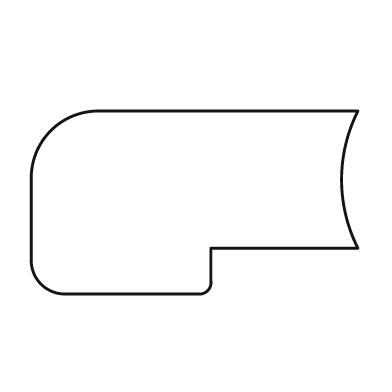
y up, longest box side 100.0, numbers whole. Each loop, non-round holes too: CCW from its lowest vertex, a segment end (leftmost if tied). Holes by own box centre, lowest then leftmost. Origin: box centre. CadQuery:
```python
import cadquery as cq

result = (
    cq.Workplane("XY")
    .moveTo(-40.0, -28.0)
    .lineTo(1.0, -28.0)
    .threePointArc((4.0, -27.0), (5.0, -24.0))
    .lineTo(5.0, -14.0)
    .lineTo(50.0, -14.0)
    .threePointArc((45.0, 7.0), (50.0, 28.0))
    .lineTo(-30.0, 28.0)
    .threePointArc((-44.0, 22.0), (-50.0, 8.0))
    .lineTo(-50.0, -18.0)
    .threePointArc((-47.0, -25.0), (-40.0, -28.0))
    .close()
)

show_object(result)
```